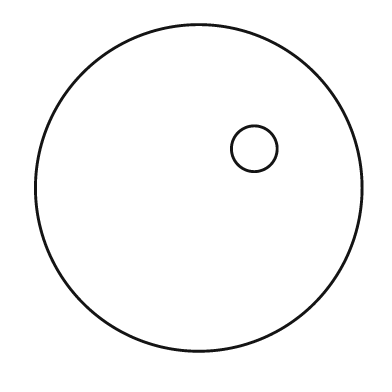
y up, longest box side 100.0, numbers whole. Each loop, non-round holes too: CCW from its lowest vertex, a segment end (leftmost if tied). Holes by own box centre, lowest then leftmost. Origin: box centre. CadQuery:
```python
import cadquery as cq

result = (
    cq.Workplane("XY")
    .moveTo(0.0, 0.0)
    .circle(50.0)
    .moveTo(17.0, 12.0)
    .circle(7.0)
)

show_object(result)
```